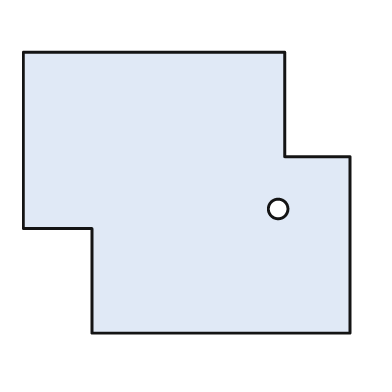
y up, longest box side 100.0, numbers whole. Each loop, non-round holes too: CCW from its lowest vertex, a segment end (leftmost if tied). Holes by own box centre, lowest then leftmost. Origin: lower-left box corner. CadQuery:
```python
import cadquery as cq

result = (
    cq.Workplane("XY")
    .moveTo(21.0, 0.0)
    .lineTo(100.0, 0.0)
    .lineTo(100.0, 54.0)
    .lineTo(80.0, 54.0)
    .lineTo(80.0, 86.0)
    .lineTo(0.0, 86.0)
    .lineTo(0.0, 32.0)
    .lineTo(21.0, 32.0)
    .close()
    .moveTo(78.0, 38.0)
    .circle(3.0)
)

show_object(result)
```